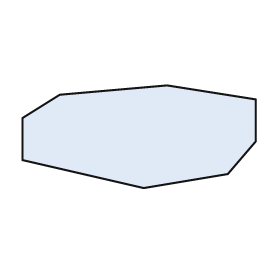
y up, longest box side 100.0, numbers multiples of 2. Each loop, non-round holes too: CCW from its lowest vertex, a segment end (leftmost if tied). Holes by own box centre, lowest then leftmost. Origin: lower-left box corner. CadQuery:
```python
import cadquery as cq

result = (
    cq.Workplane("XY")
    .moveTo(52.0, 0.0)
    .lineTo(88.0, 6.0)
    .lineTo(100.0, 20.0)
    .lineTo(100.0, 38.0)
    .lineTo(62.0, 44.0)
    .lineTo(16.0, 40.0)
    .lineTo(0.0, 30.0)
    .lineTo(0.0, 12.0)
    .close()
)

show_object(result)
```